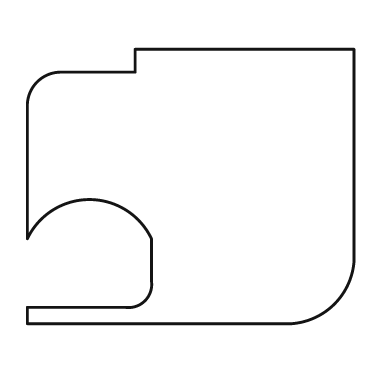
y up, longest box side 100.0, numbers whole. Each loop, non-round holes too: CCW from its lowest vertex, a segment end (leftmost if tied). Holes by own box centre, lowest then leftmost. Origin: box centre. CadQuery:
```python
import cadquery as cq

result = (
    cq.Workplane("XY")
    .moveTo(-50.0, -42.0)
    .lineTo(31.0, -42.0)
    .threePointArc((44.0, -36.0), (50.0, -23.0))
    .lineTo(50.0, 42.0)
    .lineTo(-17.0, 42.0)
    .lineTo(-17.0, 35.0)
    .lineTo(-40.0, 35.0)
    .threePointArc((-47.0, 32.0), (-50.0, 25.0))
    .lineTo(-50.0, -16.0)
    .threePointArc((-31.0, -4.0), (-12.0, -16.0))
    .lineTo(-12.0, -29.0)
    .threePointArc((-14.0, -35.0), (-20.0, -37.0))
    .lineTo(-50.0, -37.0)
    .close()
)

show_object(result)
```